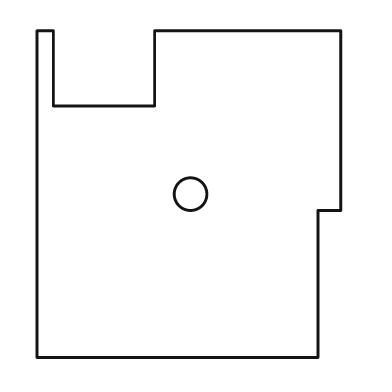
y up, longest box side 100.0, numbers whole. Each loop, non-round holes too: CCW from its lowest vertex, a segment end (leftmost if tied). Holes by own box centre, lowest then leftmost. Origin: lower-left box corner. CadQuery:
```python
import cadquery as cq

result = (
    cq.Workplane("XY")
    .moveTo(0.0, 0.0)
    .lineTo(86.0, 0.0)
    .lineTo(86.0, 45.0)
    .lineTo(93.0, 45.0)
    .lineTo(93.0, 100.0)
    .lineTo(36.0, 100.0)
    .lineTo(36.0, 77.0)
    .lineTo(5.0, 77.0)
    .lineTo(5.0, 100.0)
    .lineTo(0.0, 100.0)
    .close()
    .moveTo(47.0, 50.0)
    .circle(5.0)
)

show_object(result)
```